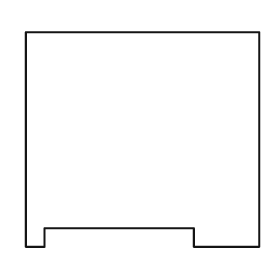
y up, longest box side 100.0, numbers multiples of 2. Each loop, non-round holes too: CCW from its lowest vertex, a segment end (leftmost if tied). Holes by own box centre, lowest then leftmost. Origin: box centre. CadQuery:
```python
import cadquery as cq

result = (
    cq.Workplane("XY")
    .moveTo(-50.0, -46.0)
    .lineTo(-42.0, -46.0)
    .lineTo(-42.0, -38.0)
    .lineTo(22.0, -38.0)
    .lineTo(22.0, -46.0)
    .lineTo(50.0, -46.0)
    .lineTo(50.0, 46.0)
    .lineTo(-50.0, 46.0)
    .close()
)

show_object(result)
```